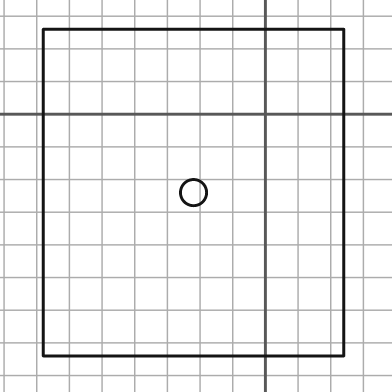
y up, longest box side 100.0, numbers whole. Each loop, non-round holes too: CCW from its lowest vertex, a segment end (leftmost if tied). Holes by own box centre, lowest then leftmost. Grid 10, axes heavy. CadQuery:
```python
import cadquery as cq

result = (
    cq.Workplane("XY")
    .moveTo(-68.0, -74.0)
    .lineTo(24.0, -74.0)
    .lineTo(24.0, 26.0)
    .lineTo(-68.0, 26.0)
    .close()
    .moveTo(-22.0, -24.0)
    .circle(4.0)
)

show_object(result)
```